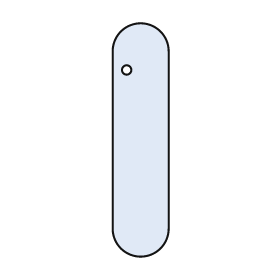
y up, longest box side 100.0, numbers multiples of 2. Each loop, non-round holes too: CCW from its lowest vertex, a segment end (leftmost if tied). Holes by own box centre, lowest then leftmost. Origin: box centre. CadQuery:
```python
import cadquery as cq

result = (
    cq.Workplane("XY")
    .moveTo(-12.0, -38.0)
    .threePointArc((0.0, -50.0), (12.0, -38.0))
    .lineTo(12.0, 38.0)
    .threePointArc((0.0, 50.0), (-12.0, 38.0))
    .close()
    .moveTo(-6.0, 30.0)
    .circle(2.0)
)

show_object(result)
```